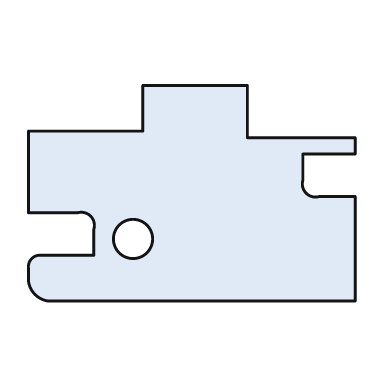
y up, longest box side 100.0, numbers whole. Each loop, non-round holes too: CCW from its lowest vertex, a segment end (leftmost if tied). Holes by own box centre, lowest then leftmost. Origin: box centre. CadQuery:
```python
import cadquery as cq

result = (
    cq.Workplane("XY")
    .moveTo(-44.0, -33.0)
    .lineTo(50.0, -33.0)
    .lineTo(50.0, -1.0)
    .lineTo(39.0, -1.0)
    .threePointArc((35.0, 0.0), (34.0, 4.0))
    .lineTo(34.0, 12.0)
    .lineTo(50.0, 12.0)
    .lineTo(50.0, 17.0)
    .lineTo(17.0, 17.0)
    .lineTo(17.0, 33.0)
    .lineTo(-15.0, 33.0)
    .lineTo(-15.0, 19.0)
    .lineTo(-50.0, 19.0)
    .lineTo(-50.0, -6.0)
    .lineTo(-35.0, -6.0)
    .threePointArc((-31.0, -7.0), (-30.0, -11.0))
    .lineTo(-30.0, -19.0)
    .lineTo(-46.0, -19.0)
    .threePointArc((-49.0, -20.0), (-50.0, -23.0))
    .lineTo(-50.0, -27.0)
    .threePointArc((-48.0, -31.0), (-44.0, -33.0))
    .close()
    .moveTo(-18.0, -14.0)
    .circle(6.0)
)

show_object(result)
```